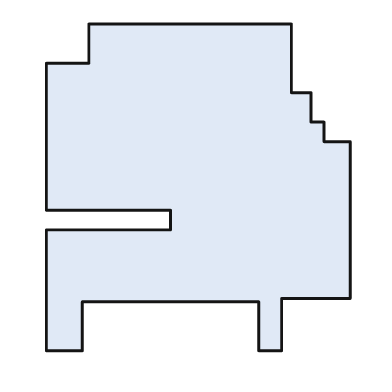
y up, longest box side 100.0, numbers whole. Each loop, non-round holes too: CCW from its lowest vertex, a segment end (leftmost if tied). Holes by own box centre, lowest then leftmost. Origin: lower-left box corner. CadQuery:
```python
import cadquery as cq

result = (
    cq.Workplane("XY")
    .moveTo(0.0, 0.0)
    .lineTo(11.0, 0.0)
    .lineTo(11.0, 15.0)
    .lineTo(65.0, 15.0)
    .lineTo(65.0, 0.0)
    .lineTo(72.0, 0.0)
    .lineTo(72.0, 16.0)
    .lineTo(93.0, 16.0)
    .lineTo(93.0, 64.0)
    .lineTo(85.0, 64.0)
    .lineTo(85.0, 70.0)
    .lineTo(81.0, 70.0)
    .lineTo(81.0, 79.0)
    .lineTo(75.0, 79.0)
    .lineTo(75.0, 100.0)
    .lineTo(13.0, 100.0)
    .lineTo(13.0, 88.0)
    .lineTo(0.0, 88.0)
    .lineTo(0.0, 43.0)
    .lineTo(38.0, 43.0)
    .lineTo(38.0, 37.0)
    .lineTo(0.0, 37.0)
    .close()
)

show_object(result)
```